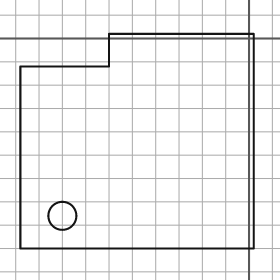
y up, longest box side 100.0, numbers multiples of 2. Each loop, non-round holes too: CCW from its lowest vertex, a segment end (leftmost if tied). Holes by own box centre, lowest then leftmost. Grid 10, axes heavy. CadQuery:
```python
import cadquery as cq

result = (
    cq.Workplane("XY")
    .moveTo(-98.0, -90.0)
    .lineTo(2.0, -90.0)
    .lineTo(2.0, 2.0)
    .lineTo(-60.0, 2.0)
    .lineTo(-60.0, -12.0)
    .lineTo(-98.0, -12.0)
    .close()
    .moveTo(-80.0, -76.0)
    .circle(6.0)
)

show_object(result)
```